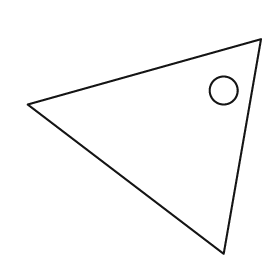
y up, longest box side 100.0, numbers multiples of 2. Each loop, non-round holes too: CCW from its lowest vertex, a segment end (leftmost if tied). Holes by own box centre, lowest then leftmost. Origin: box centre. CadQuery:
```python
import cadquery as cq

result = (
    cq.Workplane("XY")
    .moveTo(34.0, -46.0)
    .lineTo(50.0, 46.0)
    .lineTo(-50.0, 18.0)
    .close()
    .moveTo(34.0, 24.0)
    .circle(6.0)
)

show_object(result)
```